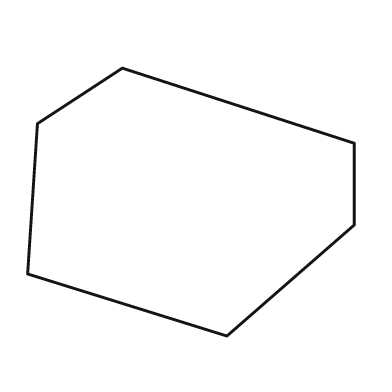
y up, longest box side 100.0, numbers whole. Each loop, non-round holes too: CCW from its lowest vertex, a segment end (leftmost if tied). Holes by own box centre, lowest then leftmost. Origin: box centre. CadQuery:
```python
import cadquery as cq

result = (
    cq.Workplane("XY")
    .moveTo(11.0, -41.0)
    .lineTo(50.0, -7.0)
    .lineTo(50.0, 18.0)
    .lineTo(-21.0, 41.0)
    .lineTo(-47.0, 24.0)
    .lineTo(-50.0, -22.0)
    .close()
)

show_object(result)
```